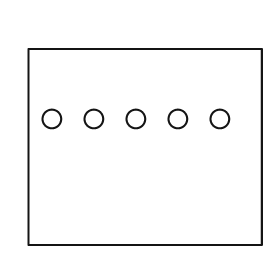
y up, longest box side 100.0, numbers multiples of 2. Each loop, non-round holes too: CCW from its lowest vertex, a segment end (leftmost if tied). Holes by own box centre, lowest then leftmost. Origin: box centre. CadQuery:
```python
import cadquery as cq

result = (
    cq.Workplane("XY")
    .moveTo(-50.0, -42.0)
    .lineTo(50.0, -42.0)
    .lineTo(50.0, 42.0)
    .lineTo(-50.0, 42.0)
    .close()
    .moveTo(-40.0, 12.0)
    .circle(4.0)
    .moveTo(-22.0, 12.0)
    .circle(4.0)
    .moveTo(-4.0, 12.0)
    .circle(4.0)
    .moveTo(14.0, 12.0)
    .circle(4.0)
    .moveTo(32.0, 12.0)
    .circle(4.0)
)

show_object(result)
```